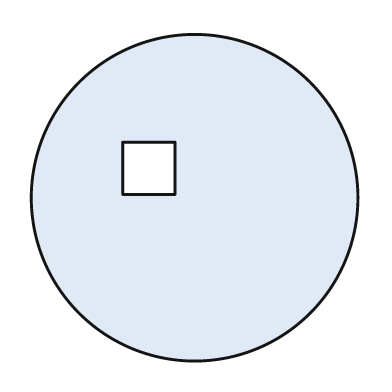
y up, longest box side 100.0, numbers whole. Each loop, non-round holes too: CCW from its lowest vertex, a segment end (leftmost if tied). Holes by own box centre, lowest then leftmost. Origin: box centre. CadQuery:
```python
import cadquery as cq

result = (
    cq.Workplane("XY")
    .moveTo(0.0, 0.0)
    .circle(50.0)
    .moveTo(-22.0, 1.0)
    .lineTo(-6.0, 1.0)
    .lineTo(-6.0, 17.0)
    .lineTo(-22.0, 17.0)
    .close()
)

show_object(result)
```